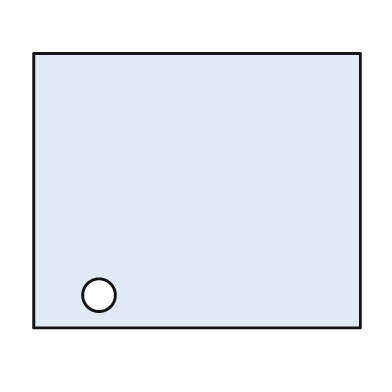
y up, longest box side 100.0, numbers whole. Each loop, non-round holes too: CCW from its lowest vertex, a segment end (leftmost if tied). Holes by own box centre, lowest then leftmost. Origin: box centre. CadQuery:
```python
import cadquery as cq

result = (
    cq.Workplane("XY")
    .moveTo(-50.0, -42.0)
    .lineTo(50.0, -42.0)
    .lineTo(50.0, 42.0)
    .lineTo(-50.0, 42.0)
    .close()
    .moveTo(-30.0, -32.0)
    .circle(5.0)
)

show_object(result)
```